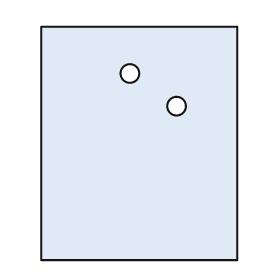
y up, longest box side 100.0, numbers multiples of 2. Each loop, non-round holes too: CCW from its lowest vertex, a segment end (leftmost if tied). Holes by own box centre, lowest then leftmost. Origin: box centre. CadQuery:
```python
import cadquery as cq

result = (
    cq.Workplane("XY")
    .moveTo(-42.0, -50.0)
    .lineTo(42.0, -50.0)
    .lineTo(42.0, 50.0)
    .lineTo(-42.0, 50.0)
    .close()
    .moveTo(16.0, 16.0)
    .circle(4.0)
    .moveTo(-4.0, 30.0)
    .circle(4.0)
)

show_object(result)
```